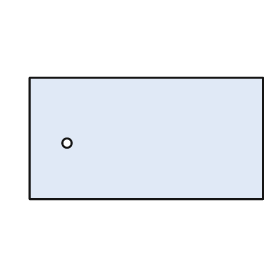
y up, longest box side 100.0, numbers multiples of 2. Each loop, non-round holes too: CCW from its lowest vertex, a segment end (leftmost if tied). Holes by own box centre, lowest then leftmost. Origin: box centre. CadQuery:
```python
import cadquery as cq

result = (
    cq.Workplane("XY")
    .moveTo(-50.0, -26.0)
    .lineTo(50.0, -26.0)
    .lineTo(50.0, 26.0)
    .lineTo(-50.0, 26.0)
    .close()
    .moveTo(-34.0, -2.0)
    .circle(2.0)
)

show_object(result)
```